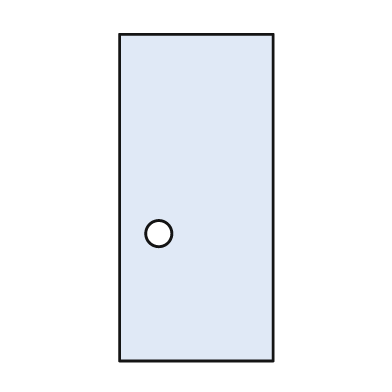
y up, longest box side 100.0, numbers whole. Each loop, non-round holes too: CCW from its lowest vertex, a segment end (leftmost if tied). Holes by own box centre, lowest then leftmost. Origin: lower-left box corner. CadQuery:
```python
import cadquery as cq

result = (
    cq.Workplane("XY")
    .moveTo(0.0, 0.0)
    .lineTo(47.0, 0.0)
    .lineTo(47.0, 100.0)
    .lineTo(0.0, 100.0)
    .close()
    .moveTo(12.0, 39.0)
    .circle(4.0)
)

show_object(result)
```